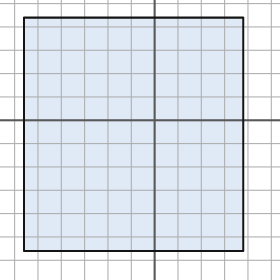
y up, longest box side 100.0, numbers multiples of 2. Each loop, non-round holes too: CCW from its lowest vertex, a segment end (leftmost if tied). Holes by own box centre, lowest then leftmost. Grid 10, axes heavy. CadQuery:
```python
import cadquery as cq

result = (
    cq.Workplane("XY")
    .moveTo(-56.0, -56.0)
    .lineTo(38.0, -56.0)
    .lineTo(38.0, 44.0)
    .lineTo(-56.0, 44.0)
    .close()
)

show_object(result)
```